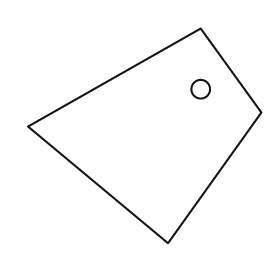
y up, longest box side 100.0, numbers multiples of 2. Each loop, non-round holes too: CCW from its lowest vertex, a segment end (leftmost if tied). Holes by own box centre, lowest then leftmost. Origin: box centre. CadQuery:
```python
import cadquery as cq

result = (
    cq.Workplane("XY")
    .moveTo(10.0, -46.0)
    .lineTo(50.0, 10.0)
    .lineTo(24.0, 46.0)
    .lineTo(-50.0, 4.0)
    .close()
    .moveTo(24.0, 20.0)
    .circle(4.0)
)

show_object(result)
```